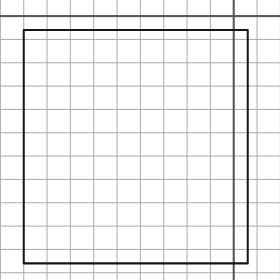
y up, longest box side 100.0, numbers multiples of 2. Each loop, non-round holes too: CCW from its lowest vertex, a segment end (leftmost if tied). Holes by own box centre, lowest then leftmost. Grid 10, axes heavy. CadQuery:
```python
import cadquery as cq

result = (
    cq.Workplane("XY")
    .moveTo(-90.0, -106.0)
    .lineTo(6.0, -106.0)
    .lineTo(6.0, -6.0)
    .lineTo(-90.0, -6.0)
    .close()
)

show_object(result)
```